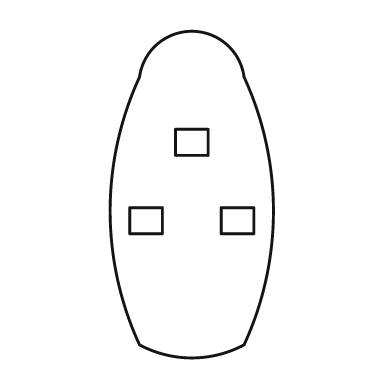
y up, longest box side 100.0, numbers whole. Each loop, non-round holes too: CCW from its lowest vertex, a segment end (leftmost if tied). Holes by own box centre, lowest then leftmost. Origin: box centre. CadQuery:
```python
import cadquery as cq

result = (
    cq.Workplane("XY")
    .moveTo(-16.0, -46.0)
    .threePointArc((0.0, -50.0), (16.0, -46.0))
    .threePointArc((25.0, -5.0), (16.0, 36.0))
    .threePointArc((0.0, 50.0), (-16.0, 36.0))
    .threePointArc((-25.0, -5.0), (-16.0, -46.0))
    .close()
    .moveTo(-19.0, -12.0)
    .lineTo(-9.0, -12.0)
    .lineTo(-9.0, -4.0)
    .lineTo(-19.0, -4.0)
    .close()
    .moveTo(9.0, -12.0)
    .lineTo(19.0, -12.0)
    .lineTo(19.0, -4.0)
    .lineTo(9.0, -4.0)
    .close()
    .moveTo(-5.0, 12.0)
    .lineTo(5.0, 12.0)
    .lineTo(5.0, 20.0)
    .lineTo(-5.0, 20.0)
    .close()
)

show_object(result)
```